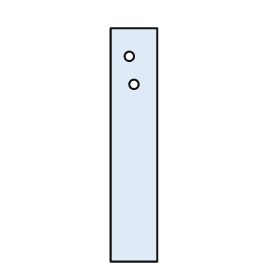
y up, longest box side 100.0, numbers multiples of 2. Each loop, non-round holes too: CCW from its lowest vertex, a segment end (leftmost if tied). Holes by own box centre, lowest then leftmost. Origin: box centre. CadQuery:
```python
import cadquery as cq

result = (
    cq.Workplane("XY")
    .moveTo(-10.0, -50.0)
    .lineTo(10.0, -50.0)
    .lineTo(10.0, 50.0)
    .lineTo(-10.0, 50.0)
    .close()
    .moveTo(0.0, 26.0)
    .circle(2.0)
    .moveTo(-2.0, 38.0)
    .circle(2.0)
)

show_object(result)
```